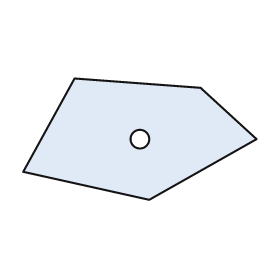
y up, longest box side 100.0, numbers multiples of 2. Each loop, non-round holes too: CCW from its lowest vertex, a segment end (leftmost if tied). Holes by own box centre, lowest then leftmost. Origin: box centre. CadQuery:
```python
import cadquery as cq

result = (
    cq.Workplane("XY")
    .moveTo(4.0, -26.0)
    .lineTo(50.0, 0.0)
    .lineTo(26.0, 22.0)
    .lineTo(-28.0, 26.0)
    .lineTo(-50.0, -14.0)
    .close()
    .moveTo(0.0, 0.0)
    .circle(4.0)
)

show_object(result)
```